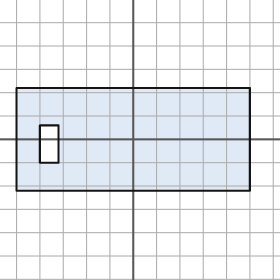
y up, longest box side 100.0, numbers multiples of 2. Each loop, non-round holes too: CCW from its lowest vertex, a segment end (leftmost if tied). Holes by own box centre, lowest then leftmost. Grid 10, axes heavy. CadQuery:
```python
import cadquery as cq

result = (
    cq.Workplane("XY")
    .moveTo(-50.0, -22.0)
    .lineTo(50.0, -22.0)
    .lineTo(50.0, 22.0)
    .lineTo(-50.0, 22.0)
    .close()
    .moveTo(-40.0, -10.0)
    .lineTo(-32.0, -10.0)
    .lineTo(-32.0, 6.0)
    .lineTo(-40.0, 6.0)
    .close()
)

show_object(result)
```